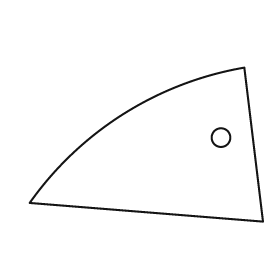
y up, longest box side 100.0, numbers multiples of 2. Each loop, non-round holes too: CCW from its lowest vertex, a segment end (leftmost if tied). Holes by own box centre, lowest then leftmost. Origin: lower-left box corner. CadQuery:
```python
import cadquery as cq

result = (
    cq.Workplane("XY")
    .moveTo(100.0, 0.0)
    .lineTo(92.0, 66.0)
    .threePointArc((40.0, 46.0), (0.0, 8.0))
    .close()
    .moveTo(82.0, 36.0)
    .circle(4.0)
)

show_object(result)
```